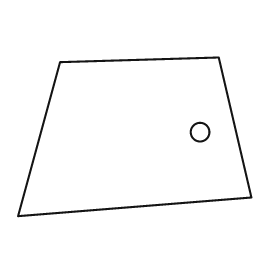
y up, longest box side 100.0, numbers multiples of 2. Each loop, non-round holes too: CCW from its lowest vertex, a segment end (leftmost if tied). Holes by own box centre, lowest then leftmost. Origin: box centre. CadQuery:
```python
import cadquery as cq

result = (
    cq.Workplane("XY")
    .moveTo(-50.0, -34.0)
    .lineTo(50.0, -26.0)
    .lineTo(36.0, 34.0)
    .lineTo(-32.0, 32.0)
    .close()
    .moveTo(28.0, 2.0)
    .circle(4.0)
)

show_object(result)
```